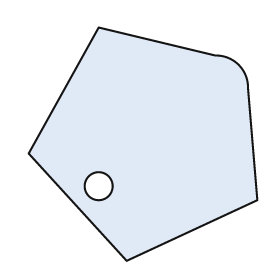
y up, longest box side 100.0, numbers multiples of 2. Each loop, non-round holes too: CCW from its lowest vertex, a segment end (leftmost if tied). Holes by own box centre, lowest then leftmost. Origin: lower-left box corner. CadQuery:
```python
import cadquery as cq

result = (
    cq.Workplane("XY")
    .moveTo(42.0, 0.0)
    .lineTo(98.0, 26.0)
    .lineTo(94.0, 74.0)
    .threePointArc((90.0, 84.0), (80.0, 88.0))
    .lineTo(30.0, 100.0)
    .lineTo(0.0, 46.0)
    .close()
    .moveTo(30.0, 32.0)
    .circle(6.0)
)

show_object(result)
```